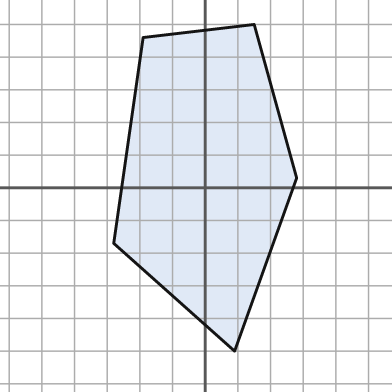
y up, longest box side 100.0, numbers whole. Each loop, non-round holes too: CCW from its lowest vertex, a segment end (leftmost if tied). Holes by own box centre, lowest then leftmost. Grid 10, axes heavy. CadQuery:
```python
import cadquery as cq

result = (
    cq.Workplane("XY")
    .moveTo(9.0, -50.0)
    .lineTo(28.0, 3.0)
    .lineTo(15.0, 50.0)
    .lineTo(-19.0, 46.0)
    .lineTo(-28.0, -17.0)
    .close()
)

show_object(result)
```